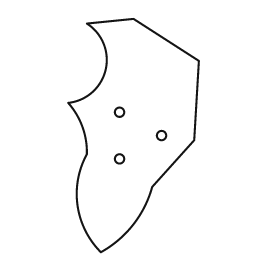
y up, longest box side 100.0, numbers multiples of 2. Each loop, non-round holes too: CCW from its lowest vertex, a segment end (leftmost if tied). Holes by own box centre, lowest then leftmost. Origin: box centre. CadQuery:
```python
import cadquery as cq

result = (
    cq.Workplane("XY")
    .moveTo(-14.0, -50.0)
    .threePointArc((0.0, -38.0), (8.0, -22.0))
    .lineTo(26.0, -2.0)
    .lineTo(28.0, 32.0)
    .lineTo(0.0, 50.0)
    .lineTo(-20.0, 48.0)
    .threePointArc((-12.0, 28.0), (-28.0, 14.0))
    .threePointArc((-22.0, 4.0), (-20.0, -8.0))
    .threePointArc((-24.0, -30.0), (-14.0, -50.0))
    .close()
    .moveTo(-6.0, -10.0)
    .circle(2.0)
    .moveTo(12.0, 0.0)
    .circle(2.0)
    .moveTo(-6.0, 10.0)
    .circle(2.0)
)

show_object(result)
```